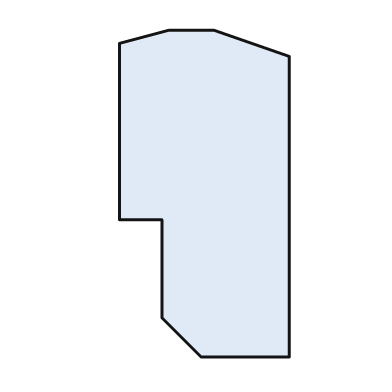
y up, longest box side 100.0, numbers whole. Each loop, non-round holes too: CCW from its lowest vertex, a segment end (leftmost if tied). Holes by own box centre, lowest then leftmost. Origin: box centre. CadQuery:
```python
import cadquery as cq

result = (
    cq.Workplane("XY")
    .moveTo(-1.0, -50.0)
    .lineTo(26.0, -50.0)
    .lineTo(26.0, 42.0)
    .lineTo(3.0, 50.0)
    .lineTo(-11.0, 50.0)
    .lineTo(-26.0, 46.0)
    .lineTo(-26.0, -8.0)
    .lineTo(-13.0, -8.0)
    .lineTo(-13.0, -38.0)
    .close()
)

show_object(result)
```